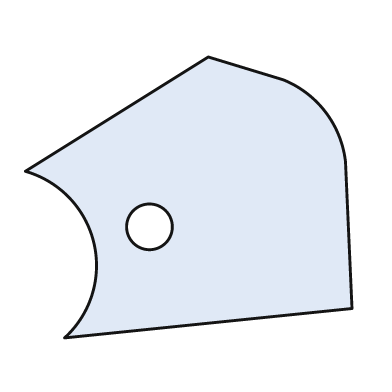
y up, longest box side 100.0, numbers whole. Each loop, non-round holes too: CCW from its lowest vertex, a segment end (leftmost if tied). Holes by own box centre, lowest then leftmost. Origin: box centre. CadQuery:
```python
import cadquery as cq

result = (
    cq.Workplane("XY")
    .moveTo(-38.0, -43.0)
    .lineTo(50.0, -34.0)
    .lineTo(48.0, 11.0)
    .threePointArc((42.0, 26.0), (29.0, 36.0))
    .lineTo(6.0, 43.0)
    .lineTo(-50.0, 8.0)
    .threePointArc((-29.0, -14.0), (-38.0, -43.0))
    .close()
    .moveTo(-12.0, -9.0)
    .circle(7.0)
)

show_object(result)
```